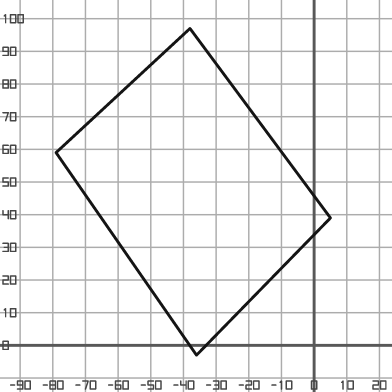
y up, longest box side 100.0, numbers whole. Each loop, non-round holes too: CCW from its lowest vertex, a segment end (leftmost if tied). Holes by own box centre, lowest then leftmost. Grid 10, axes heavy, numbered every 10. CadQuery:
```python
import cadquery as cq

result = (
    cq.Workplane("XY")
    .moveTo(-36.0, -3.0)
    .lineTo(5.0, 39.0)
    .lineTo(-38.0, 97.0)
    .lineTo(-79.0, 59.0)
    .close()
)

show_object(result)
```